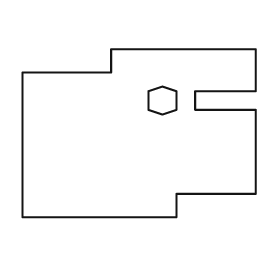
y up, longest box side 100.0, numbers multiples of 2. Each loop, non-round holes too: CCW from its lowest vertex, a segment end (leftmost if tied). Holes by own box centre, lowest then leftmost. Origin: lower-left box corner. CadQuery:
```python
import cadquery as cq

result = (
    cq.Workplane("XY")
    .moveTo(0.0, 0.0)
    .lineTo(66.0, 0.0)
    .lineTo(66.0, 10.0)
    .lineTo(100.0, 10.0)
    .lineTo(100.0, 46.0)
    .lineTo(74.0, 46.0)
    .lineTo(74.0, 54.0)
    .lineTo(100.0, 54.0)
    .lineTo(100.0, 72.0)
    .lineTo(38.0, 72.0)
    .lineTo(38.0, 62.0)
    .lineTo(0.0, 62.0)
    .close()
    .moveTo(60.0, 44.0)
    .lineTo(66.0, 46.0)
    .lineTo(66.0, 54.0)
    .lineTo(60.0, 56.0)
    .lineTo(54.0, 54.0)
    .lineTo(54.0, 46.0)
    .close()
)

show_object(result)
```